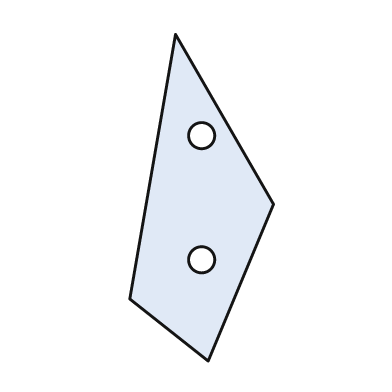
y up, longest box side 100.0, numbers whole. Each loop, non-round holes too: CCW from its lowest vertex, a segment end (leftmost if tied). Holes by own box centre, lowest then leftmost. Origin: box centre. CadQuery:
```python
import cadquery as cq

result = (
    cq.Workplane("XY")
    .moveTo(2.0, -50.0)
    .lineTo(22.0, -2.0)
    .lineTo(-8.0, 50.0)
    .lineTo(-22.0, -31.0)
    .close()
    .moveTo(0.0, -19.0)
    .circle(4.0)
    .moveTo(0.0, 19.0)
    .circle(4.0)
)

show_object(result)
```